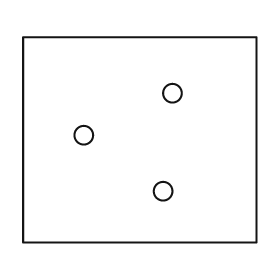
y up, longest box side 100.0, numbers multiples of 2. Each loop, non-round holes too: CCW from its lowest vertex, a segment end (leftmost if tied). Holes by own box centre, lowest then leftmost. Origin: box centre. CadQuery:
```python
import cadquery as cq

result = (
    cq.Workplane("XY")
    .moveTo(-50.0, -44.0)
    .lineTo(50.0, -44.0)
    .lineTo(50.0, 44.0)
    .lineTo(-50.0, 44.0)
    .close()
    .moveTo(10.0, -22.0)
    .circle(4.0)
    .moveTo(-24.0, 2.0)
    .circle(4.0)
    .moveTo(14.0, 20.0)
    .circle(4.0)
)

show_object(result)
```